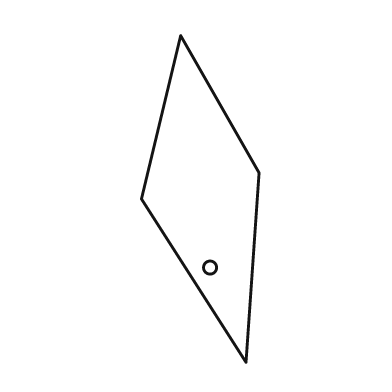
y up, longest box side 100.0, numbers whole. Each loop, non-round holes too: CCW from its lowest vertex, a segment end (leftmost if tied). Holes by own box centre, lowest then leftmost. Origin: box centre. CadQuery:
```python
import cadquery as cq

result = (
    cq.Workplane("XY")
    .moveTo(14.0, -50.0)
    .lineTo(18.0, 8.0)
    .lineTo(-6.0, 50.0)
    .lineTo(-18.0, 0.0)
    .close()
    .moveTo(3.0, -21.0)
    .circle(2.0)
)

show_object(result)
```